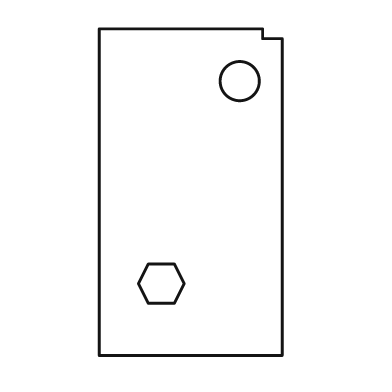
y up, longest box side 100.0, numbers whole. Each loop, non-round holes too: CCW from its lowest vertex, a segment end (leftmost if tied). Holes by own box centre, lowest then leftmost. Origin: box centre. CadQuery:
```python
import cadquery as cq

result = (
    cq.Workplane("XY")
    .moveTo(-28.0, -50.0)
    .lineTo(28.0, -50.0)
    .lineTo(28.0, 47.0)
    .lineTo(22.0, 47.0)
    .lineTo(22.0, 50.0)
    .lineTo(-28.0, 50.0)
    .close()
    .moveTo(-13.0, -34.0)
    .lineTo(-5.0, -34.0)
    .lineTo(-2.0, -28.0)
    .lineTo(-5.0, -22.0)
    .lineTo(-13.0, -22.0)
    .lineTo(-16.0, -28.0)
    .close()
    .moveTo(15.0, 34.0)
    .circle(6.0)
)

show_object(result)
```